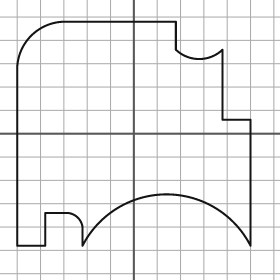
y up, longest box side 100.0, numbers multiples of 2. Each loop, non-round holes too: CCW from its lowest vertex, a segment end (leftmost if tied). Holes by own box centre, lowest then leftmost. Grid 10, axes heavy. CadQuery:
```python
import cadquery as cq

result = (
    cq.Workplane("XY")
    .moveTo(-50.0, -48.0)
    .lineTo(-38.0, -48.0)
    .lineTo(-38.0, -34.0)
    .lineTo(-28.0, -34.0)
    .threePointArc((-24.0, -36.0), (-22.0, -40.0))
    .lineTo(-22.0, -48.0)
    .threePointArc((14.0, -26.0), (50.0, -48.0))
    .lineTo(50.0, 6.0)
    .lineTo(38.0, 6.0)
    .lineTo(38.0, 36.0)
    .threePointArc((28.0, 32.0), (18.0, 36.0))
    .lineTo(18.0, 48.0)
    .lineTo(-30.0, 48.0)
    .threePointArc((-44.0, 42.0), (-50.0, 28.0))
    .close()
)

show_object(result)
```